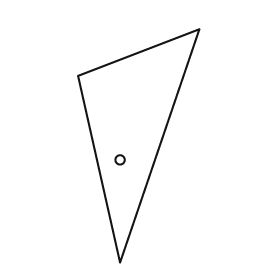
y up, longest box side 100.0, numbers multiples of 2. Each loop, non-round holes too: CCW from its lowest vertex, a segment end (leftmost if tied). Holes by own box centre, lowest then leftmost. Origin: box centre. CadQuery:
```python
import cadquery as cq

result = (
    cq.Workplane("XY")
    .moveTo(-8.0, -50.0)
    .lineTo(26.0, 50.0)
    .lineTo(-26.0, 30.0)
    .close()
    .moveTo(-8.0, -6.0)
    .circle(2.0)
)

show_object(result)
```